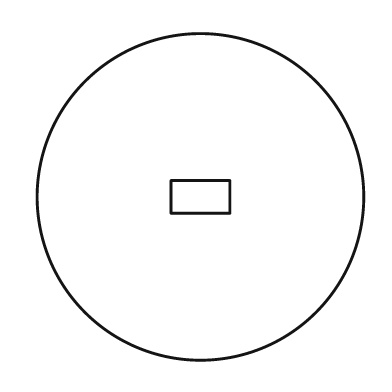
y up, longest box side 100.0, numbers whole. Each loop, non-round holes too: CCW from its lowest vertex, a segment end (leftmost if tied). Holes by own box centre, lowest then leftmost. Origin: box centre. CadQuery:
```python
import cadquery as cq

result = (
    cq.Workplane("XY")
    .moveTo(0.0, 0.0)
    .circle(50.0)
    .moveTo(-9.0, -5.0)
    .lineTo(9.0, -5.0)
    .lineTo(9.0, 5.0)
    .lineTo(-9.0, 5.0)
    .close()
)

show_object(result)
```